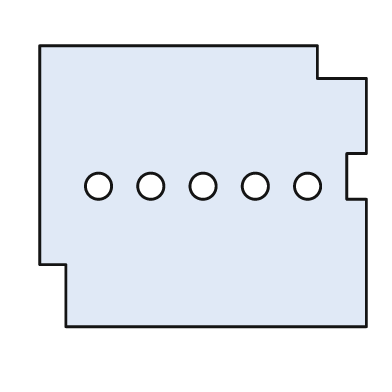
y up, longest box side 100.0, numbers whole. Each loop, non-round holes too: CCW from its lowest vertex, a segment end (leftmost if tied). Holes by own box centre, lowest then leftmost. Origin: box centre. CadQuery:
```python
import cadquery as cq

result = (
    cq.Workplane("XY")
    .moveTo(-42.0, -43.0)
    .lineTo(50.0, -43.0)
    .lineTo(50.0, -4.0)
    .lineTo(44.0, -4.0)
    .lineTo(44.0, 10.0)
    .lineTo(50.0, 10.0)
    .lineTo(50.0, 33.0)
    .lineTo(35.0, 33.0)
    .lineTo(35.0, 43.0)
    .lineTo(-50.0, 43.0)
    .lineTo(-50.0, -24.0)
    .lineTo(-42.0, -24.0)
    .close()
    .moveTo(-32.0, 0.0)
    .circle(4.0)
    .moveTo(-16.0, 0.0)
    .circle(4.0)
    .moveTo(0.0, 0.0)
    .circle(4.0)
    .moveTo(16.0, 0.0)
    .circle(4.0)
    .moveTo(32.0, 0.0)
    .circle(4.0)
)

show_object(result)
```